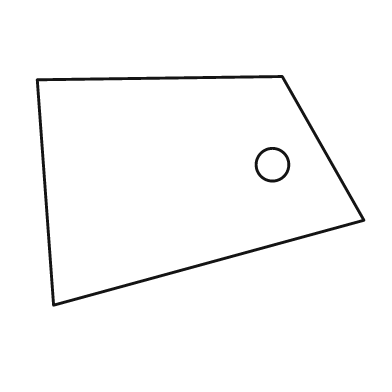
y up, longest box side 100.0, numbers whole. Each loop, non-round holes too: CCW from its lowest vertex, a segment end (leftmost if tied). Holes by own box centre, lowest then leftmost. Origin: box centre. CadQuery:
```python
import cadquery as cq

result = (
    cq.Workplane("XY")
    .moveTo(-45.0, -35.0)
    .lineTo(50.0, -9.0)
    .lineTo(25.0, 35.0)
    .lineTo(-50.0, 34.0)
    .close()
    .moveTo(22.0, 8.0)
    .circle(5.0)
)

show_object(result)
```